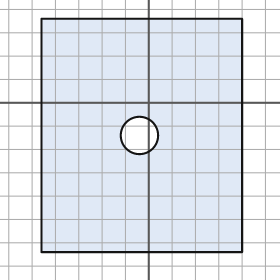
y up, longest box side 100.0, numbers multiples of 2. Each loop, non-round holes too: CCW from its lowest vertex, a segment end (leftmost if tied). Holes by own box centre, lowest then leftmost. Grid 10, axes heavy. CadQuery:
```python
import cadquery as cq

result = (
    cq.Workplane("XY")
    .moveTo(-46.0, -64.0)
    .lineTo(40.0, -64.0)
    .lineTo(40.0, 36.0)
    .lineTo(-46.0, 36.0)
    .close()
    .moveTo(-4.0, -14.0)
    .circle(8.0)
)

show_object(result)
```